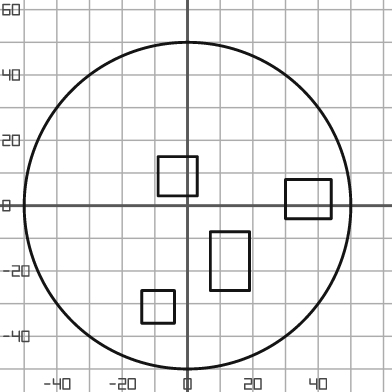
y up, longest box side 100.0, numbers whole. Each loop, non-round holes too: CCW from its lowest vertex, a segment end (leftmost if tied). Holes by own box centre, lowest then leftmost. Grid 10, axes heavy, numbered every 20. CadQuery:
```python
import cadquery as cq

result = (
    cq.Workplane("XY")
    .moveTo(0.0, 0.0)
    .circle(50.0)
    .moveTo(-14.0, -36.0)
    .lineTo(-4.0, -36.0)
    .lineTo(-4.0, -26.0)
    .lineTo(-14.0, -26.0)
    .close()
    .moveTo(7.0, -26.0)
    .lineTo(19.0, -26.0)
    .lineTo(19.0, -8.0)
    .lineTo(7.0, -8.0)
    .close()
    .moveTo(30.0, -4.0)
    .lineTo(44.0, -4.0)
    .lineTo(44.0, 8.0)
    .lineTo(30.0, 8.0)
    .close()
    .moveTo(-9.0, 3.0)
    .lineTo(3.0, 3.0)
    .lineTo(3.0, 15.0)
    .lineTo(-9.0, 15.0)
    .close()
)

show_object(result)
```